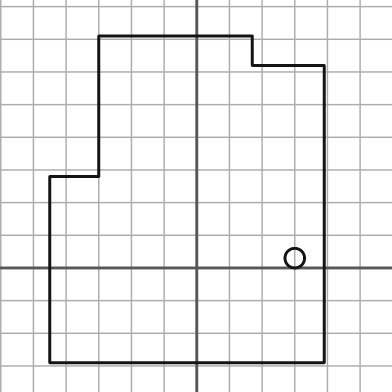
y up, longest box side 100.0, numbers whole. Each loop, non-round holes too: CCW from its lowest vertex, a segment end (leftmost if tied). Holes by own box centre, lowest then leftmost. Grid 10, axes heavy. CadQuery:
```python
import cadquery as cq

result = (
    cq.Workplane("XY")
    .moveTo(-45.0, -29.0)
    .lineTo(39.0, -29.0)
    .lineTo(39.0, 62.0)
    .lineTo(17.0, 62.0)
    .lineTo(17.0, 71.0)
    .lineTo(-30.0, 71.0)
    .lineTo(-30.0, 28.0)
    .lineTo(-45.0, 28.0)
    .close()
    .moveTo(30.0, 3.0)
    .circle(3.0)
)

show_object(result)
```